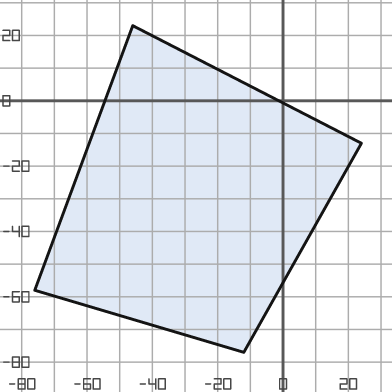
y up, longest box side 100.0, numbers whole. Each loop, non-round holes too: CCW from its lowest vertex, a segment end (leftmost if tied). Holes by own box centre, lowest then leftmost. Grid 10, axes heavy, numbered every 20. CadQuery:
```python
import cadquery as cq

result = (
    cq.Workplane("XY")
    .moveTo(-12.0, -77.0)
    .lineTo(24.0, -13.0)
    .lineTo(-46.0, 23.0)
    .lineTo(-76.0, -58.0)
    .close()
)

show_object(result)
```